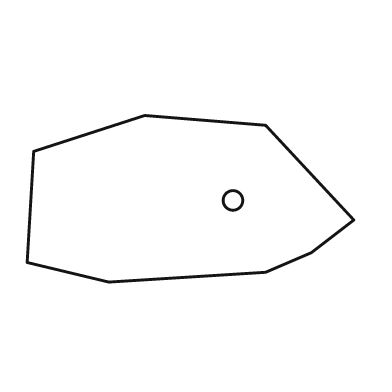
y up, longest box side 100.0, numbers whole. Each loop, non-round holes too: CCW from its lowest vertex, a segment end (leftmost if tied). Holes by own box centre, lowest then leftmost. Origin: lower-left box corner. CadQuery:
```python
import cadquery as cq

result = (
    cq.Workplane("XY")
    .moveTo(25.0, 0.0)
    .lineTo(73.0, 3.0)
    .lineTo(87.0, 9.0)
    .lineTo(100.0, 19.0)
    .lineTo(73.0, 48.0)
    .lineTo(36.0, 51.0)
    .lineTo(2.0, 40.0)
    .lineTo(0.0, 6.0)
    .close()
    .moveTo(63.0, 25.0)
    .circle(3.0)
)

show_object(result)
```